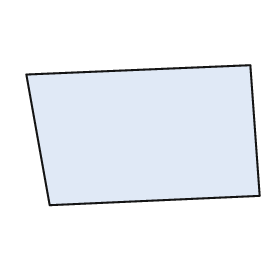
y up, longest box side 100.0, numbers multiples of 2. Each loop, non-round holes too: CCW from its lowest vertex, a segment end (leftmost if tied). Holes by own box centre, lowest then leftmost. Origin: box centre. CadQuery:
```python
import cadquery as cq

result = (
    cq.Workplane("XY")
    .moveTo(-40.0, -30.0)
    .lineTo(50.0, -26.0)
    .lineTo(46.0, 30.0)
    .lineTo(-50.0, 26.0)
    .close()
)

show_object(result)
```